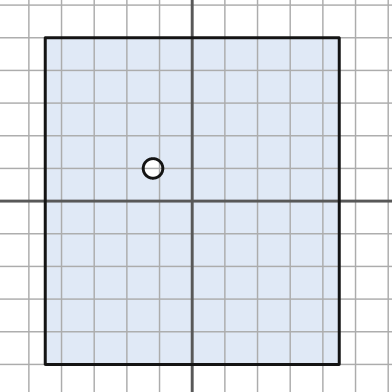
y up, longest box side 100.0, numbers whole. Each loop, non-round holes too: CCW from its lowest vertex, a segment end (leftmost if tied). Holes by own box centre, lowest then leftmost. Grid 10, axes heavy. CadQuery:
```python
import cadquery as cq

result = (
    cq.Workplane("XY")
    .moveTo(-45.0, -50.0)
    .lineTo(45.0, -50.0)
    .lineTo(45.0, 50.0)
    .lineTo(-45.0, 50.0)
    .close()
    .moveTo(-12.0, 10.0)
    .circle(3.0)
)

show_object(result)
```